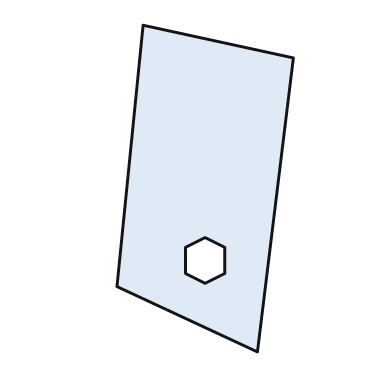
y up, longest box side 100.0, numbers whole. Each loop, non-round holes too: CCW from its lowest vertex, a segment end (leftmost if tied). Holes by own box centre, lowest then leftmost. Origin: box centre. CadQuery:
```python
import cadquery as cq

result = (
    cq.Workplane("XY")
    .moveTo(16.0, -50.0)
    .lineTo(27.0, 40.0)
    .lineTo(-19.0, 50.0)
    .lineTo(-27.0, -30.0)
    .close()
    .moveTo(0.0, -29.0)
    .lineTo(6.0, -26.0)
    .lineTo(6.0, -18.0)
    .lineTo(0.0, -15.0)
    .lineTo(-6.0, -18.0)
    .lineTo(-6.0, -26.0)
    .close()
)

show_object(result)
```